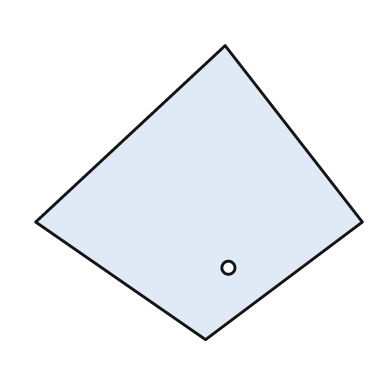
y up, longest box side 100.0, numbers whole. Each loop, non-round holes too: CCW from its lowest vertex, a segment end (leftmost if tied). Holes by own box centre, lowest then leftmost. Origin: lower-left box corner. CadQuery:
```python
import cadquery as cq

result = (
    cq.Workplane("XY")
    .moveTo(52.0, 0.0)
    .lineTo(100.0, 36.0)
    .lineTo(58.0, 90.0)
    .lineTo(0.0, 36.0)
    .close()
    .moveTo(59.0, 22.0)
    .circle(2.0)
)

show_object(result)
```